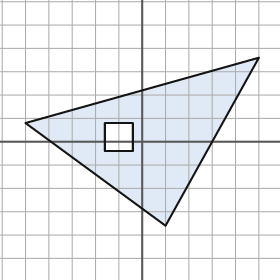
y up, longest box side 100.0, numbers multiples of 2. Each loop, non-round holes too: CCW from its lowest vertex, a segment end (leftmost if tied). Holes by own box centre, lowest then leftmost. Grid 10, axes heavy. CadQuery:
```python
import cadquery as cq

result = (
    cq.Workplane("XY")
    .moveTo(10.0, -36.0)
    .lineTo(50.0, 36.0)
    .lineTo(-50.0, 8.0)
    .close()
    .moveTo(-16.0, -4.0)
    .lineTo(-4.0, -4.0)
    .lineTo(-4.0, 8.0)
    .lineTo(-16.0, 8.0)
    .close()
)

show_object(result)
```